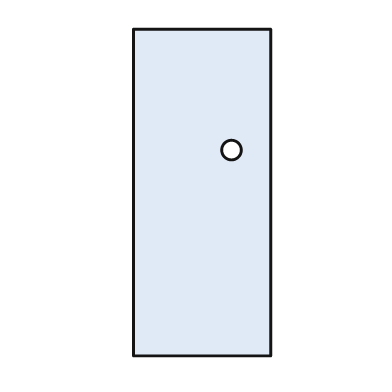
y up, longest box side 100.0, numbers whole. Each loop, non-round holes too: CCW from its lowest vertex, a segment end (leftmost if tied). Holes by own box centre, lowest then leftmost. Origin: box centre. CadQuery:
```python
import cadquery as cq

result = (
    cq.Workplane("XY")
    .moveTo(-21.0, -50.0)
    .lineTo(21.0, -50.0)
    .lineTo(21.0, 50.0)
    .lineTo(-21.0, 50.0)
    .close()
    .moveTo(9.0, 13.0)
    .circle(3.0)
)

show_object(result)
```